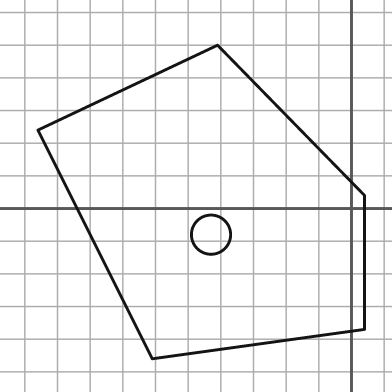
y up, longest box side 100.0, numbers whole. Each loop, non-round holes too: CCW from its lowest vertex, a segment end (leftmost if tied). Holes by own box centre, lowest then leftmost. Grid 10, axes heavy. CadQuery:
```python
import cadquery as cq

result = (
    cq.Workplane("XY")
    .moveTo(-61.0, -46.0)
    .lineTo(4.0, -37.0)
    .lineTo(4.0, 4.0)
    .lineTo(-41.0, 50.0)
    .lineTo(-96.0, 24.0)
    .close()
    .moveTo(-43.0, -8.0)
    .circle(6.0)
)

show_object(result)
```